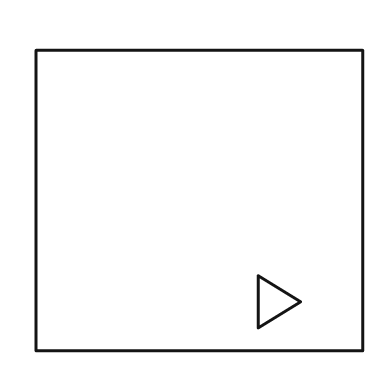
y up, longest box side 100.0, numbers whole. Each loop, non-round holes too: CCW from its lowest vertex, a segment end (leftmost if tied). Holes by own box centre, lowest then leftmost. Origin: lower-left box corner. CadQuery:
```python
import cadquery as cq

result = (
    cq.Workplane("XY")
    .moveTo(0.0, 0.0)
    .lineTo(100.0, 0.0)
    .lineTo(100.0, 92.0)
    .lineTo(0.0, 92.0)
    .close()
    .moveTo(68.0, 7.0)
    .lineTo(81.0, 15.0)
    .lineTo(68.0, 23.0)
    .close()
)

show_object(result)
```